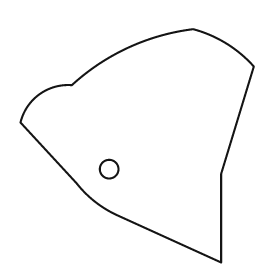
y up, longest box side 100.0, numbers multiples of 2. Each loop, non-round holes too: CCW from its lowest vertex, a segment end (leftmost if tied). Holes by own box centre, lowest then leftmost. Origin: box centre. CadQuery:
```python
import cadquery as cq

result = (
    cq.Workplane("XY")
    .moveTo(36.0, -50.0)
    .lineTo(36.0, -12.0)
    .lineTo(50.0, 34.0)
    .threePointArc((38.0, 44.0), (24.0, 50.0))
    .threePointArc((-4.0, 42.0), (-28.0, 26.0))
    .threePointArc((-42.0, 22.0), (-50.0, 10.0))
    .lineTo(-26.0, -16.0)
    .threePointArc((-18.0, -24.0), (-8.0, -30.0))
    .close()
    .moveTo(-12.0, -10.0)
    .circle(4.0)
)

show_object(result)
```